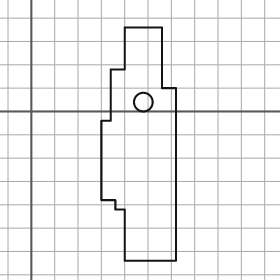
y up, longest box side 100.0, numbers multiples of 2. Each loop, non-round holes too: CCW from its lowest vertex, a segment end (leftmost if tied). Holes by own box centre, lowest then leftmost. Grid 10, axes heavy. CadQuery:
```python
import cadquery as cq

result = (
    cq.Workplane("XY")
    .moveTo(40.0, -64.0)
    .lineTo(62.0, -64.0)
    .lineTo(62.0, 10.0)
    .lineTo(56.0, 10.0)
    .lineTo(56.0, 36.0)
    .lineTo(40.0, 36.0)
    .lineTo(40.0, 18.0)
    .lineTo(34.0, 18.0)
    .lineTo(34.0, -4.0)
    .lineTo(30.0, -4.0)
    .lineTo(30.0, -38.0)
    .lineTo(36.0, -38.0)
    .lineTo(36.0, -42.0)
    .lineTo(40.0, -42.0)
    .close()
    .moveTo(48.0, 4.0)
    .circle(4.0)
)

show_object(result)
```